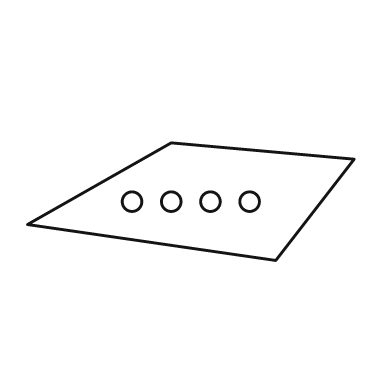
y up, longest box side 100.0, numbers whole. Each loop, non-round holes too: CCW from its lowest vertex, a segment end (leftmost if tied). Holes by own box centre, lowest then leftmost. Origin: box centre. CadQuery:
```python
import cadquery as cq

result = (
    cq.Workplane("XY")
    .moveTo(26.0, -18.0)
    .lineTo(50.0, 13.0)
    .lineTo(-6.0, 18.0)
    .lineTo(-50.0, -7.0)
    .close()
    .moveTo(-18.0, 0.0)
    .circle(3.0)
    .moveTo(-6.0, 0.0)
    .circle(3.0)
    .moveTo(6.0, 0.0)
    .circle(3.0)
    .moveTo(18.0, 0.0)
    .circle(3.0)
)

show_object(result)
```